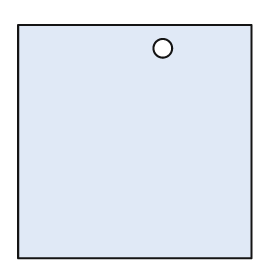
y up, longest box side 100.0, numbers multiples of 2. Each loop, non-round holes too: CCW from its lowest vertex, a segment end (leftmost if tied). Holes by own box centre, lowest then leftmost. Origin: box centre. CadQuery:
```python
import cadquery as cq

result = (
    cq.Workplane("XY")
    .moveTo(-50.0, -50.0)
    .lineTo(50.0, -50.0)
    .lineTo(50.0, 50.0)
    .lineTo(-50.0, 50.0)
    .close()
    .moveTo(12.0, 40.0)
    .circle(4.0)
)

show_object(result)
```